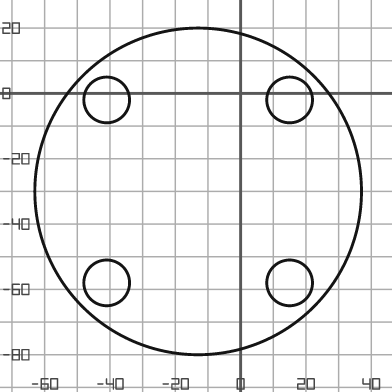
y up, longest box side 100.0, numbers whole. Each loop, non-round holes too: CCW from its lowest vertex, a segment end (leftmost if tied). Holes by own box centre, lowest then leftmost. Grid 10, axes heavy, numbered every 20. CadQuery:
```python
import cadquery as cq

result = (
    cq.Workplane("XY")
    .moveTo(-13.0, -30.0)
    .circle(50.0)
    .moveTo(-41.0, -58.0)
    .circle(7.0)
    .moveTo(15.0, -58.0)
    .circle(7.0)
    .moveTo(-41.0, -2.0)
    .circle(7.0)
    .moveTo(15.0, -2.0)
    .circle(7.0)
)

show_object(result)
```